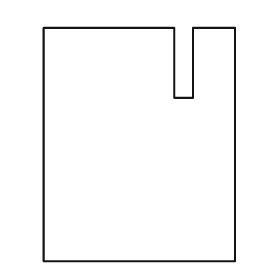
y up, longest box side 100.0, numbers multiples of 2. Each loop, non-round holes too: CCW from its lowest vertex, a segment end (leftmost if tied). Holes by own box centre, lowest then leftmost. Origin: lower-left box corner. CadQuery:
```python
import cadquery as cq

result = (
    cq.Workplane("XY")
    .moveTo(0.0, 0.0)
    .lineTo(82.0, 0.0)
    .lineTo(82.0, 100.0)
    .lineTo(64.0, 100.0)
    .lineTo(64.0, 70.0)
    .lineTo(56.0, 70.0)
    .lineTo(56.0, 100.0)
    .lineTo(0.0, 100.0)
    .close()
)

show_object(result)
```